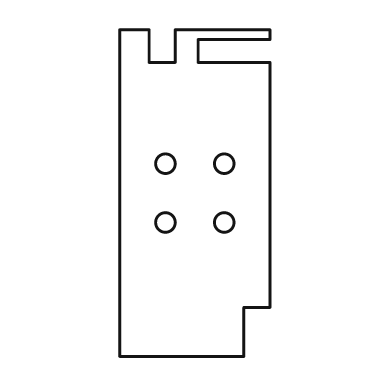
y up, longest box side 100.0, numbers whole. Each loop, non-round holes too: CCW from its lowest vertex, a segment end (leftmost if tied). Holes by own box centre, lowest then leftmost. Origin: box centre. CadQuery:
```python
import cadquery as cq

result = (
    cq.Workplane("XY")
    .moveTo(-23.0, -50.0)
    .lineTo(15.0, -50.0)
    .lineTo(15.0, -35.0)
    .lineTo(23.0, -35.0)
    .lineTo(23.0, 40.0)
    .lineTo(1.0, 40.0)
    .lineTo(1.0, 47.0)
    .lineTo(23.0, 47.0)
    .lineTo(23.0, 50.0)
    .lineTo(-6.0, 50.0)
    .lineTo(-6.0, 40.0)
    .lineTo(-14.0, 40.0)
    .lineTo(-14.0, 50.0)
    .lineTo(-23.0, 50.0)
    .close()
    .moveTo(-9.0, -9.0)
    .circle(3.0)
    .moveTo(9.0, -9.0)
    .circle(3.0)
    .moveTo(-9.0, 9.0)
    .circle(3.0)
    .moveTo(9.0, 9.0)
    .circle(3.0)
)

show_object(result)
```